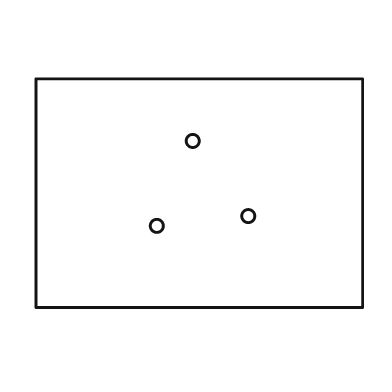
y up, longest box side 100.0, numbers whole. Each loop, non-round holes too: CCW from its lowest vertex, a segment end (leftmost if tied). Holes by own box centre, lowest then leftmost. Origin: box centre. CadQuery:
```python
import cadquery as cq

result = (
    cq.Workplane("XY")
    .moveTo(-50.0, -35.0)
    .lineTo(50.0, -35.0)
    .lineTo(50.0, 35.0)
    .lineTo(-50.0, 35.0)
    .close()
    .moveTo(-13.0, -10.0)
    .circle(2.0)
    .moveTo(15.0, -7.0)
    .circle(2.0)
    .moveTo(-2.0, 16.0)
    .circle(2.0)
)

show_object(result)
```